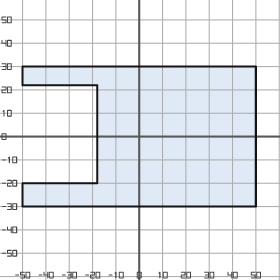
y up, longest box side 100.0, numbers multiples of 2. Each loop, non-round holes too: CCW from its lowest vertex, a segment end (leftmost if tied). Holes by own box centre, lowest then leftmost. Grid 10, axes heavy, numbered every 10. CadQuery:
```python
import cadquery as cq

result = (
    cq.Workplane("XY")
    .moveTo(-50.0, -30.0)
    .lineTo(50.0, -30.0)
    .lineTo(50.0, 30.0)
    .lineTo(-50.0, 30.0)
    .lineTo(-50.0, 22.0)
    .lineTo(-18.0, 22.0)
    .lineTo(-18.0, -20.0)
    .lineTo(-50.0, -20.0)
    .close()
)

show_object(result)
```